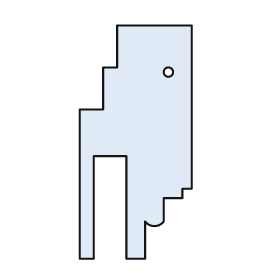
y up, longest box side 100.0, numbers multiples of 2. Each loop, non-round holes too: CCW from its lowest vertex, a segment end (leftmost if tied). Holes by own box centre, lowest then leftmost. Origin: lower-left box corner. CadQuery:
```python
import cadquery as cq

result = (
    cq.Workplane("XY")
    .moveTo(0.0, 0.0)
    .lineTo(6.0, 0.0)
    .lineTo(6.0, 44.0)
    .lineTo(20.0, 44.0)
    .lineTo(20.0, 0.0)
    .lineTo(28.0, 0.0)
    .lineTo(28.0, 16.0)
    .threePointArc((32.0, 14.0), (36.0, 16.0))
    .lineTo(36.0, 26.0)
    .lineTo(44.0, 26.0)
    .lineTo(44.0, 30.0)
    .lineTo(48.0, 30.0)
    .lineTo(48.0, 100.0)
    .lineTo(16.0, 100.0)
    .lineTo(16.0, 82.0)
    .lineTo(10.0, 82.0)
    .lineTo(10.0, 64.0)
    .lineTo(0.0, 64.0)
    .close()
    .moveTo(38.0, 80.0)
    .circle(2.0)
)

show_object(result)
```